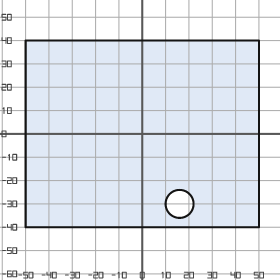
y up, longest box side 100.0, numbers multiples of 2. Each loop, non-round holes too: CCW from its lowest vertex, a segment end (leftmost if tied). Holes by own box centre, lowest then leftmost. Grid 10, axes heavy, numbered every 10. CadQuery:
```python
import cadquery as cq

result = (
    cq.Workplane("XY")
    .moveTo(-50.0, -40.0)
    .lineTo(50.0, -40.0)
    .lineTo(50.0, 40.0)
    .lineTo(-50.0, 40.0)
    .close()
    .moveTo(16.0, -30.0)
    .circle(6.0)
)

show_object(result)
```